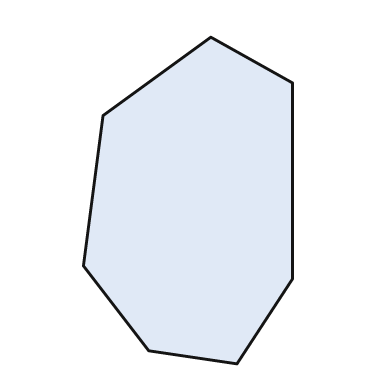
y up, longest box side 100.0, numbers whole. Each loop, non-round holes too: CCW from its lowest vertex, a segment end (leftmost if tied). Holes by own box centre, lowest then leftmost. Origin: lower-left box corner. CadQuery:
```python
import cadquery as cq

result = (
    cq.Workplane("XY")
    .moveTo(47.0, 0.0)
    .lineTo(64.0, 26.0)
    .lineTo(64.0, 86.0)
    .lineTo(39.0, 100.0)
    .lineTo(6.0, 76.0)
    .lineTo(0.0, 30.0)
    .lineTo(20.0, 4.0)
    .close()
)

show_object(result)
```